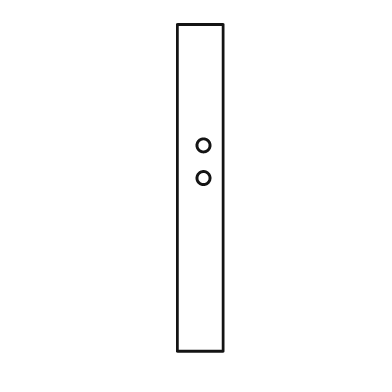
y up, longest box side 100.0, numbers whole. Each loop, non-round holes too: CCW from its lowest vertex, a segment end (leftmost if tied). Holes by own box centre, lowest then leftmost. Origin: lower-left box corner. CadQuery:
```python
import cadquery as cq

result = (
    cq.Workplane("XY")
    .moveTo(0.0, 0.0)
    .lineTo(14.0, 0.0)
    .lineTo(14.0, 100.0)
    .lineTo(0.0, 100.0)
    .close()
    .moveTo(8.0, 53.0)
    .circle(2.0)
    .moveTo(8.0, 63.0)
    .circle(2.0)
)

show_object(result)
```